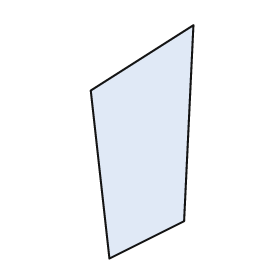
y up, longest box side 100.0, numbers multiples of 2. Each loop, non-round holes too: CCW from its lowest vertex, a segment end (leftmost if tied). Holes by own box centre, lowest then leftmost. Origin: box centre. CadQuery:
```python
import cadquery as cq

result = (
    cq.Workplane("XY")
    .moveTo(-14.0, -50.0)
    .lineTo(18.0, -34.0)
    .lineTo(22.0, 50.0)
    .lineTo(-22.0, 22.0)
    .close()
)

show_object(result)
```